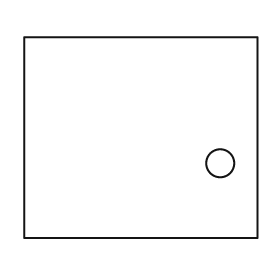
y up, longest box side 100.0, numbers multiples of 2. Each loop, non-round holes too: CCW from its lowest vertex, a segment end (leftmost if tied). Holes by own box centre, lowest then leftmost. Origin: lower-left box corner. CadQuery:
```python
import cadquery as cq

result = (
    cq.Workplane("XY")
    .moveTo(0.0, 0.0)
    .lineTo(100.0, 0.0)
    .lineTo(100.0, 86.0)
    .lineTo(0.0, 86.0)
    .close()
    .moveTo(84.0, 32.0)
    .circle(6.0)
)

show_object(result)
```